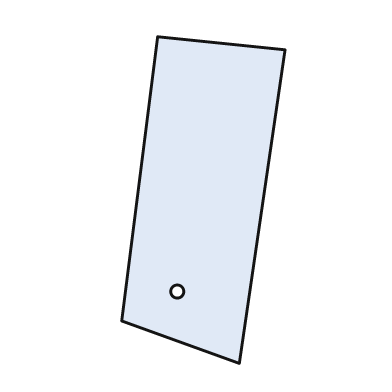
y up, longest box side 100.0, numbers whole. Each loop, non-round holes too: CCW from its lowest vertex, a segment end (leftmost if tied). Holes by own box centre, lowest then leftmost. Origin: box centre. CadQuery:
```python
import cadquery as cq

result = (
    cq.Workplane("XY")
    .moveTo(11.0, -50.0)
    .lineTo(25.0, 46.0)
    .lineTo(-14.0, 50.0)
    .lineTo(-25.0, -37.0)
    .close()
    .moveTo(-8.0, -28.0)
    .circle(2.0)
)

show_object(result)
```